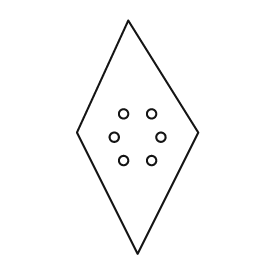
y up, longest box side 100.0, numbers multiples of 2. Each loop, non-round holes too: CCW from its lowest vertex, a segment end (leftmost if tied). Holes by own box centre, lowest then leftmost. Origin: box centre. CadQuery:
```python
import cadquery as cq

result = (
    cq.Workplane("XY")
    .moveTo(0.0, -50.0)
    .lineTo(26.0, 2.0)
    .lineTo(-4.0, 50.0)
    .lineTo(-26.0, 2.0)
    .close()
    .moveTo(-6.0, -10.0)
    .circle(2.0)
    .moveTo(6.0, -10.0)
    .circle(2.0)
    .moveTo(-10.0, 0.0)
    .circle(2.0)
    .moveTo(10.0, 0.0)
    .circle(2.0)
    .moveTo(-6.0, 10.0)
    .circle(2.0)
    .moveTo(6.0, 10.0)
    .circle(2.0)
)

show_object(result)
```